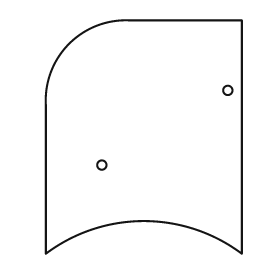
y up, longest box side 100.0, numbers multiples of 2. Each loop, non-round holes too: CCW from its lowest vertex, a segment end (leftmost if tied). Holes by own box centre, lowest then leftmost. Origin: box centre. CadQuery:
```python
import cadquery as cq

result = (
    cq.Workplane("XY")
    .moveTo(-42.0, -50.0)
    .threePointArc((0.0, -36.0), (42.0, -50.0))
    .lineTo(42.0, 50.0)
    .lineTo(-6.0, 50.0)
    .threePointArc((-32.0, 40.0), (-42.0, 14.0))
    .close()
    .moveTo(-18.0, -12.0)
    .circle(2.0)
    .moveTo(36.0, 20.0)
    .circle(2.0)
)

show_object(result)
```